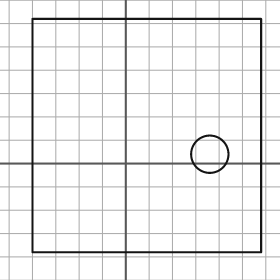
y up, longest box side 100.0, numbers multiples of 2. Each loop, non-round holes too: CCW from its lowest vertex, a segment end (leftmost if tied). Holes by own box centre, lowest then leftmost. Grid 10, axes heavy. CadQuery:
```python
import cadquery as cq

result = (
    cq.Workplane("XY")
    .moveTo(-40.0, -38.0)
    .lineTo(58.0, -38.0)
    .lineTo(58.0, 62.0)
    .lineTo(-40.0, 62.0)
    .close()
    .moveTo(36.0, 4.0)
    .circle(8.0)
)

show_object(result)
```